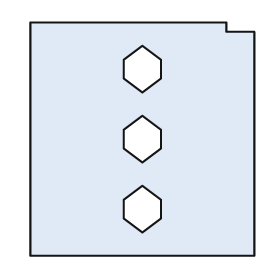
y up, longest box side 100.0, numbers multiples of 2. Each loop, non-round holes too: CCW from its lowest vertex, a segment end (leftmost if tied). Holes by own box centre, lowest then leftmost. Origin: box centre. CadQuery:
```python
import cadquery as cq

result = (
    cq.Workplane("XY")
    .moveTo(-48.0, -50.0)
    .lineTo(48.0, -50.0)
    .lineTo(48.0, 46.0)
    .lineTo(36.0, 46.0)
    .lineTo(36.0, 50.0)
    .lineTo(-48.0, 50.0)
    .close()
    .moveTo(0.0, -40.0)
    .lineTo(8.0, -34.0)
    .lineTo(8.0, -26.0)
    .lineTo(0.0, -20.0)
    .lineTo(-8.0, -26.0)
    .lineTo(-8.0, -34.0)
    .close()
    .moveTo(0.0, -10.0)
    .lineTo(8.0, -4.0)
    .lineTo(8.0, 4.0)
    .lineTo(0.0, 10.0)
    .lineTo(-8.0, 4.0)
    .lineTo(-8.0, -4.0)
    .close()
    .moveTo(0.0, 20.0)
    .lineTo(8.0, 26.0)
    .lineTo(8.0, 34.0)
    .lineTo(0.0, 40.0)
    .lineTo(-8.0, 34.0)
    .lineTo(-8.0, 26.0)
    .close()
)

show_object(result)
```